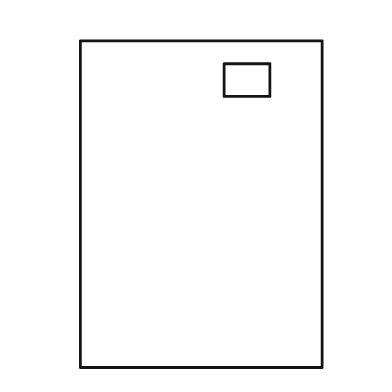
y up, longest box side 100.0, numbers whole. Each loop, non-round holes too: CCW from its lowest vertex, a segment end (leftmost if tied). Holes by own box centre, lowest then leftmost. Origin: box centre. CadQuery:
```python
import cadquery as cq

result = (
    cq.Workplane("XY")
    .moveTo(-37.0, -50.0)
    .lineTo(37.0, -50.0)
    .lineTo(37.0, 50.0)
    .lineTo(-37.0, 50.0)
    .close()
    .moveTo(7.0, 33.0)
    .lineTo(21.0, 33.0)
    .lineTo(21.0, 43.0)
    .lineTo(7.0, 43.0)
    .close()
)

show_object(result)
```